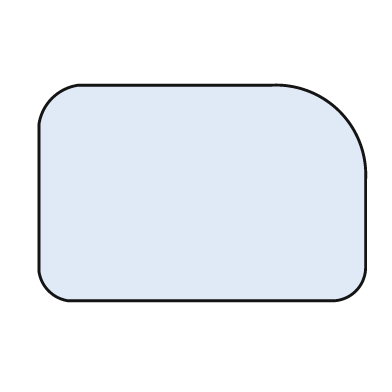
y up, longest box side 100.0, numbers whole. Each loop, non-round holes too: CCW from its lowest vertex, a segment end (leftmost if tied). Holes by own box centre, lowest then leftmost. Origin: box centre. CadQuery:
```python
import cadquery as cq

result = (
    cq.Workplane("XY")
    .moveTo(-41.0, -33.0)
    .lineTo(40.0, -33.0)
    .threePointArc((47.0, -30.0), (50.0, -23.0))
    .lineTo(50.0, 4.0)
    .threePointArc((42.0, 25.0), (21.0, 33.0))
    .lineTo(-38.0, 33.0)
    .threePointArc((-46.0, 29.0), (-50.0, 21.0))
    .lineTo(-50.0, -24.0)
    .threePointArc((-47.0, -30.0), (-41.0, -33.0))
    .close()
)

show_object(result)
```